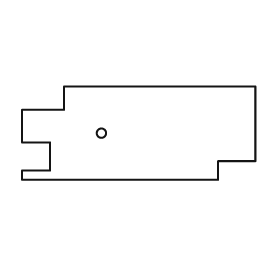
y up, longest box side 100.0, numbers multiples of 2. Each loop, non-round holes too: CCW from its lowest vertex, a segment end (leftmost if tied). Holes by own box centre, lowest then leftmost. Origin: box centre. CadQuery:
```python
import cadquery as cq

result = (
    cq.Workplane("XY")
    .moveTo(-50.0, -20.0)
    .lineTo(34.0, -20.0)
    .lineTo(34.0, -12.0)
    .lineTo(50.0, -12.0)
    .lineTo(50.0, 20.0)
    .lineTo(-32.0, 20.0)
    .lineTo(-32.0, 10.0)
    .lineTo(-50.0, 10.0)
    .lineTo(-50.0, -4.0)
    .lineTo(-38.0, -4.0)
    .lineTo(-38.0, -16.0)
    .lineTo(-50.0, -16.0)
    .close()
    .moveTo(-16.0, 0.0)
    .circle(2.0)
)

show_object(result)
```